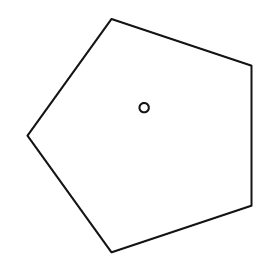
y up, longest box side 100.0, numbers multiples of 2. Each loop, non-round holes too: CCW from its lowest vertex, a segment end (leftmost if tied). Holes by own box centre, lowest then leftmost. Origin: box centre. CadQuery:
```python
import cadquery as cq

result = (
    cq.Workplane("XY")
    .moveTo(-12.0, -50.0)
    .lineTo(48.0, -30.0)
    .lineTo(48.0, 30.0)
    .lineTo(-12.0, 50.0)
    .lineTo(-48.0, 0.0)
    .close()
    .moveTo(2.0, 12.0)
    .circle(2.0)
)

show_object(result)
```